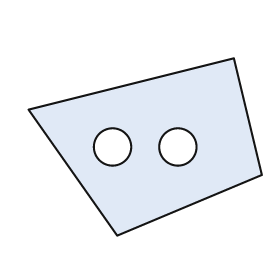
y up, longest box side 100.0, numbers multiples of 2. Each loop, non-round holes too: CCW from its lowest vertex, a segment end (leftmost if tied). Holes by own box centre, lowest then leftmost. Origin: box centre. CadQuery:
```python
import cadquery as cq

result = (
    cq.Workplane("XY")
    .moveTo(-12.0, -38.0)
    .lineTo(50.0, -12.0)
    .lineTo(38.0, 38.0)
    .lineTo(-50.0, 16.0)
    .close()
    .moveTo(-14.0, 0.0)
    .circle(8.0)
    .moveTo(14.0, 0.0)
    .circle(8.0)
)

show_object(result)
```